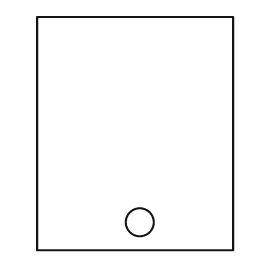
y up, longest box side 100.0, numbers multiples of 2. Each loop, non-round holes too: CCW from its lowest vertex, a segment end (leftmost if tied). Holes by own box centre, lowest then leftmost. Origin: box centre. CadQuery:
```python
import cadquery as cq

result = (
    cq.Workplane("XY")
    .moveTo(-42.0, -50.0)
    .lineTo(42.0, -50.0)
    .lineTo(42.0, 50.0)
    .lineTo(-42.0, 50.0)
    .close()
    .moveTo(2.0, -38.0)
    .circle(6.0)
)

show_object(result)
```